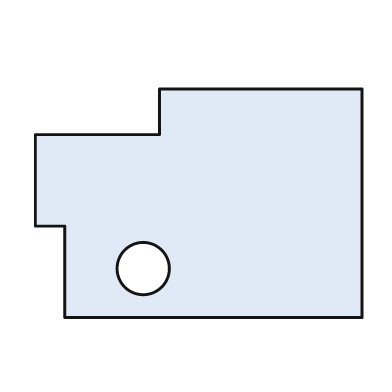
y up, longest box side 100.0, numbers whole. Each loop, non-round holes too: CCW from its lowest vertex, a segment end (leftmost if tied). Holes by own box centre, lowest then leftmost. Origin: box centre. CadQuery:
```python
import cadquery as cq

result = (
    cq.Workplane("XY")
    .moveTo(-41.0, -35.0)
    .lineTo(50.0, -35.0)
    .lineTo(50.0, 35.0)
    .lineTo(-12.0, 35.0)
    .lineTo(-12.0, 21.0)
    .lineTo(-50.0, 21.0)
    .lineTo(-50.0, -7.0)
    .lineTo(-41.0, -7.0)
    .close()
    .moveTo(-17.0, -20.0)
    .circle(8.0)
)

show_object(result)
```